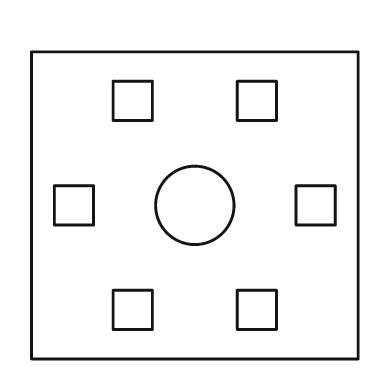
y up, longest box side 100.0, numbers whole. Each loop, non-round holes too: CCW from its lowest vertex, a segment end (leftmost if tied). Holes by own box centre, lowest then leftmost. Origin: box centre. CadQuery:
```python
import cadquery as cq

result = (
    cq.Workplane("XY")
    .moveTo(-50.0, -47.0)
    .lineTo(50.0, -47.0)
    .lineTo(50.0, 47.0)
    .lineTo(-50.0, 47.0)
    .close()
    .moveTo(-25.0, -38.0)
    .lineTo(-13.0, -38.0)
    .lineTo(-13.0, -26.0)
    .lineTo(-25.0, -26.0)
    .close()
    .moveTo(13.0, -38.0)
    .lineTo(25.0, -38.0)
    .lineTo(25.0, -26.0)
    .lineTo(13.0, -26.0)
    .close()
    .moveTo(-43.0, -6.0)
    .lineTo(-31.0, -6.0)
    .lineTo(-31.0, 6.0)
    .lineTo(-43.0, 6.0)
    .close()
    .moveTo(0.0, 0.0)
    .circle(12.0)
    .moveTo(31.0, -6.0)
    .lineTo(43.0, -6.0)
    .lineTo(43.0, 6.0)
    .lineTo(31.0, 6.0)
    .close()
    .moveTo(-25.0, 26.0)
    .lineTo(-13.0, 26.0)
    .lineTo(-13.0, 38.0)
    .lineTo(-25.0, 38.0)
    .close()
    .moveTo(13.0, 26.0)
    .lineTo(25.0, 26.0)
    .lineTo(25.0, 38.0)
    .lineTo(13.0, 38.0)
    .close()
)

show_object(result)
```